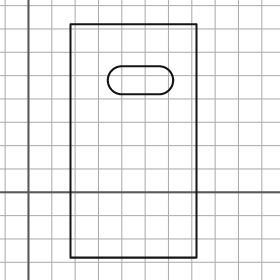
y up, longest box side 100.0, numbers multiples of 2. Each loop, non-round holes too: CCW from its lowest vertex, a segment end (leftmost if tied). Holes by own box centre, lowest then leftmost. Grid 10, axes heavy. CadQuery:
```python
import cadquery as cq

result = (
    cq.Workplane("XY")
    .moveTo(18.0, -28.0)
    .lineTo(72.0, -28.0)
    .lineTo(72.0, 72.0)
    .lineTo(18.0, 72.0)
    .close()
    .moveTo(40.0, 42.0)
    .lineTo(56.0, 42.0)
    .threePointArc((62.0, 48.0), (56.0, 54.0))
    .lineTo(40.0, 54.0)
    .threePointArc((34.0, 48.0), (40.0, 42.0))
    .close()
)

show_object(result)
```